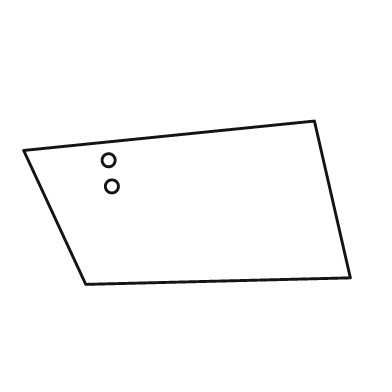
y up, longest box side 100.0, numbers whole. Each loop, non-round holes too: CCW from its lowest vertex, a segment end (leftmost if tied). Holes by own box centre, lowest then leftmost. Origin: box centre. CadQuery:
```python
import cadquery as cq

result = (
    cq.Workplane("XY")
    .moveTo(-31.0, -25.0)
    .lineTo(50.0, -23.0)
    .lineTo(39.0, 25.0)
    .lineTo(-50.0, 16.0)
    .close()
    .moveTo(-23.0, 5.0)
    .circle(2.0)
    .moveTo(-24.0, 13.0)
    .circle(2.0)
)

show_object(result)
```